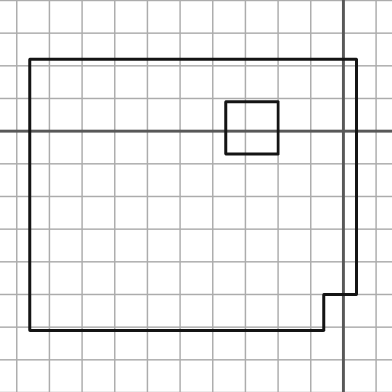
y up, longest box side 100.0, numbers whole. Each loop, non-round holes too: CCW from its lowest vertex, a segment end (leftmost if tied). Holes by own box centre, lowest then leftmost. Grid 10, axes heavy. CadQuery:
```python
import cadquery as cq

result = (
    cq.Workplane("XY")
    .moveTo(-96.0, -61.0)
    .lineTo(-6.0, -61.0)
    .lineTo(-6.0, -50.0)
    .lineTo(4.0, -50.0)
    .lineTo(4.0, 22.0)
    .lineTo(-96.0, 22.0)
    .close()
    .moveTo(-36.0, -7.0)
    .lineTo(-20.0, -7.0)
    .lineTo(-20.0, 9.0)
    .lineTo(-36.0, 9.0)
    .close()
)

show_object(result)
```